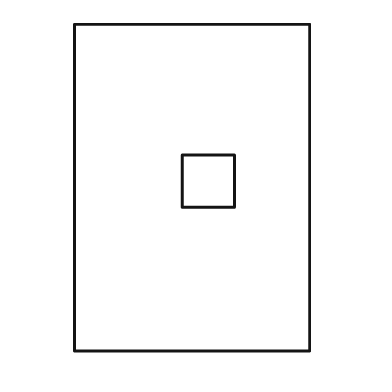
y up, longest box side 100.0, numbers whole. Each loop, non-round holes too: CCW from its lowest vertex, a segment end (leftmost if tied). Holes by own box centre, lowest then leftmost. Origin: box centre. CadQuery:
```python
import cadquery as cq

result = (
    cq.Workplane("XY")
    .moveTo(-36.0, -50.0)
    .lineTo(36.0, -50.0)
    .lineTo(36.0, 50.0)
    .lineTo(-36.0, 50.0)
    .close()
    .moveTo(-3.0, -6.0)
    .lineTo(13.0, -6.0)
    .lineTo(13.0, 10.0)
    .lineTo(-3.0, 10.0)
    .close()
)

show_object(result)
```